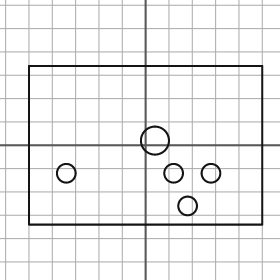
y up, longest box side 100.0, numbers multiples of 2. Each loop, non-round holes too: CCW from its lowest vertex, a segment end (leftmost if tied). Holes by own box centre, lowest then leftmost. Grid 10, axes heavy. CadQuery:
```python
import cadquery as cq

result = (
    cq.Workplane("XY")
    .moveTo(-50.0, -34.0)
    .lineTo(50.0, -34.0)
    .lineTo(50.0, 34.0)
    .lineTo(-50.0, 34.0)
    .close()
    .moveTo(18.0, -26.0)
    .circle(4.0)
    .moveTo(-34.0, -12.0)
    .circle(4.0)
    .moveTo(12.0, -12.0)
    .circle(4.0)
    .moveTo(28.0, -12.0)
    .circle(4.0)
    .moveTo(4.0, 2.0)
    .circle(6.0)
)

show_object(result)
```